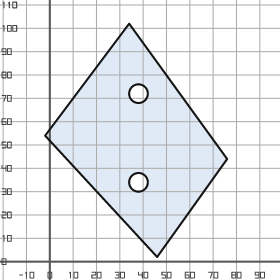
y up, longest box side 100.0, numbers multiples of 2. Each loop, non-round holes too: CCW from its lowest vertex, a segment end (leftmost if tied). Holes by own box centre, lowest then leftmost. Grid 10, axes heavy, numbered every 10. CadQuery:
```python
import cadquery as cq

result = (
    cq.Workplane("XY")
    .moveTo(46.0, 2.0)
    .lineTo(76.0, 44.0)
    .lineTo(34.0, 102.0)
    .lineTo(-2.0, 54.0)
    .close()
    .moveTo(38.0, 34.0)
    .circle(4.0)
    .moveTo(38.0, 72.0)
    .circle(4.0)
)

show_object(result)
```